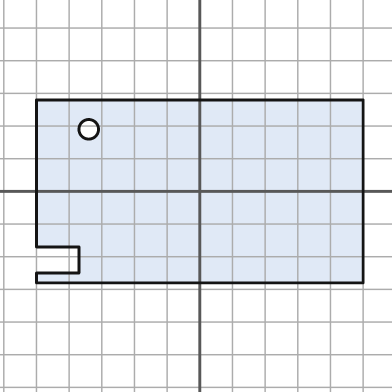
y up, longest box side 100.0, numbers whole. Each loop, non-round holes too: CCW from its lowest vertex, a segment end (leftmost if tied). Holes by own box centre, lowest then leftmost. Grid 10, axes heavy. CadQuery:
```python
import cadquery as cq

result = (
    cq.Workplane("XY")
    .moveTo(-50.0, -28.0)
    .lineTo(50.0, -28.0)
    .lineTo(50.0, 28.0)
    .lineTo(-50.0, 28.0)
    .lineTo(-50.0, -17.0)
    .lineTo(-37.0, -17.0)
    .lineTo(-37.0, -25.0)
    .lineTo(-50.0, -25.0)
    .close()
    .moveTo(-34.0, 19.0)
    .circle(3.0)
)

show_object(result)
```